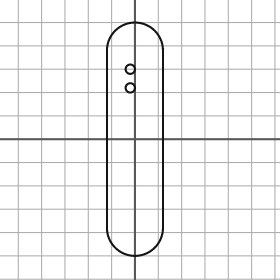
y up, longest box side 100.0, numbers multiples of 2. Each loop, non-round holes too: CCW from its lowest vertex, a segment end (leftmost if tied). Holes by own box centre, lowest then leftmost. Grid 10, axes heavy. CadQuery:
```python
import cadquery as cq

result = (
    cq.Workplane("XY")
    .moveTo(-12.0, -38.0)
    .threePointArc((0.0, -50.0), (12.0, -38.0))
    .lineTo(12.0, 38.0)
    .threePointArc((0.0, 50.0), (-12.0, 38.0))
    .close()
    .moveTo(-2.0, 22.0)
    .circle(2.0)
    .moveTo(-2.0, 30.0)
    .circle(2.0)
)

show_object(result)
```